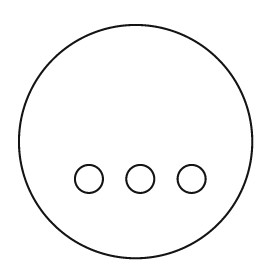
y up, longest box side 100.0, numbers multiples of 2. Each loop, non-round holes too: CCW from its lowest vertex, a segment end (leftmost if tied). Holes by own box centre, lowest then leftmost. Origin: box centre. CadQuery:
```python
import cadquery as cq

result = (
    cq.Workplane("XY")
    .moveTo(0.0, 0.0)
    .circle(50.0)
    .moveTo(-20.0, -16.0)
    .circle(6.0)
    .moveTo(2.0, -16.0)
    .circle(6.0)
    .moveTo(24.0, -16.0)
    .circle(6.0)
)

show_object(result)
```